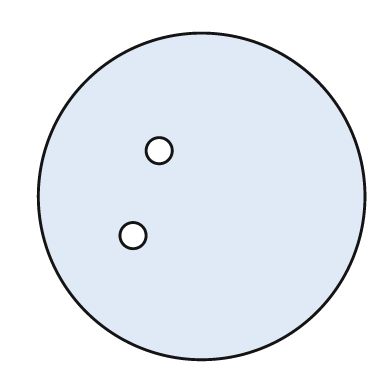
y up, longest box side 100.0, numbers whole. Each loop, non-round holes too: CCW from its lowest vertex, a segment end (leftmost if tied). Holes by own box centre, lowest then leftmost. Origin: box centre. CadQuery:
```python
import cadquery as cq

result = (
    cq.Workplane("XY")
    .moveTo(0.0, 0.0)
    .circle(50.0)
    .moveTo(-21.0, -12.0)
    .circle(4.0)
    .moveTo(-13.0, 14.0)
    .circle(4.0)
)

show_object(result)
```